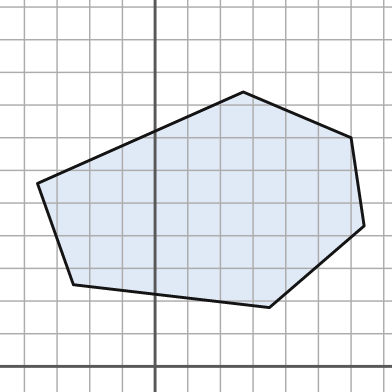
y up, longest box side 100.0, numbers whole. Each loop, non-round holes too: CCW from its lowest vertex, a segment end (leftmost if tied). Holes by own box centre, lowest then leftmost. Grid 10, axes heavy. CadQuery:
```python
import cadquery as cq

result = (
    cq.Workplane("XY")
    .moveTo(35.0, 18.0)
    .lineTo(64.0, 43.0)
    .lineTo(60.0, 70.0)
    .lineTo(27.0, 84.0)
    .lineTo(-36.0, 56.0)
    .lineTo(-25.0, 25.0)
    .close()
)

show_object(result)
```